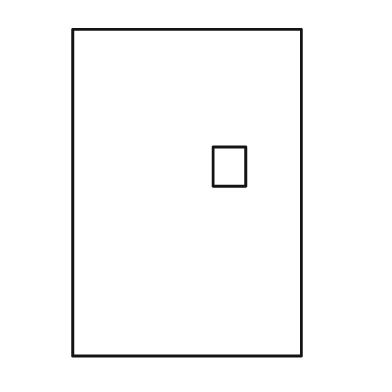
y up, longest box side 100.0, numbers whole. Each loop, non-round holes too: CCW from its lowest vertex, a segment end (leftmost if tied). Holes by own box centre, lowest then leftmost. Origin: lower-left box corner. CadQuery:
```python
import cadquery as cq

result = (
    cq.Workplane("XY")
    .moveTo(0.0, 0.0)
    .lineTo(70.0, 0.0)
    .lineTo(70.0, 100.0)
    .lineTo(0.0, 100.0)
    .close()
    .moveTo(43.0, 52.0)
    .lineTo(53.0, 52.0)
    .lineTo(53.0, 64.0)
    .lineTo(43.0, 64.0)
    .close()
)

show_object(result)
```